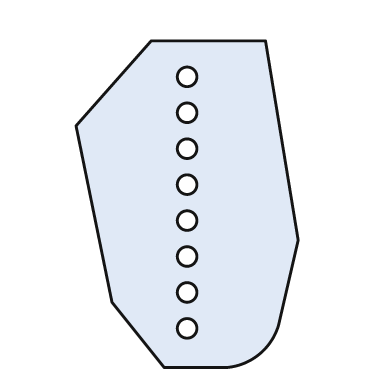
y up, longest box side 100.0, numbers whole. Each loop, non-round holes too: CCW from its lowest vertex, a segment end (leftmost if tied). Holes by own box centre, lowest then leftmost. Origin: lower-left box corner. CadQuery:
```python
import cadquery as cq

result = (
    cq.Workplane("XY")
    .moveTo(27.0, 0.0)
    .lineTo(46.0, 0.0)
    .threePointArc((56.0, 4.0), (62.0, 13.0))
    .lineTo(68.0, 39.0)
    .lineTo(58.0, 100.0)
    .lineTo(23.0, 100.0)
    .lineTo(0.0, 74.0)
    .lineTo(11.0, 20.0)
    .close()
    .moveTo(34.0, 12.0)
    .circle(3.0)
    .moveTo(34.0, 23.0)
    .circle(3.0)
    .moveTo(34.0, 34.0)
    .circle(3.0)
    .moveTo(34.0, 45.0)
    .circle(3.0)
    .moveTo(34.0, 56.0)
    .circle(3.0)
    .moveTo(34.0, 67.0)
    .circle(3.0)
    .moveTo(34.0, 78.0)
    .circle(3.0)
    .moveTo(34.0, 89.0)
    .circle(3.0)
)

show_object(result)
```